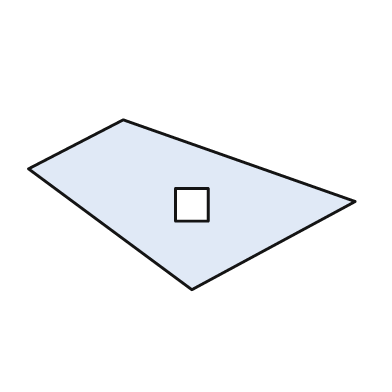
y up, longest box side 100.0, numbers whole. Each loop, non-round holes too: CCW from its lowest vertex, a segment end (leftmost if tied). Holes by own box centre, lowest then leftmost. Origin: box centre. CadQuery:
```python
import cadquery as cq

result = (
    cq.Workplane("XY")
    .moveTo(0.0, -26.0)
    .lineTo(50.0, 1.0)
    .lineTo(-21.0, 26.0)
    .lineTo(-50.0, 11.0)
    .close()
    .moveTo(-5.0, -5.0)
    .lineTo(5.0, -5.0)
    .lineTo(5.0, 5.0)
    .lineTo(-5.0, 5.0)
    .close()
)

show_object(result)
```